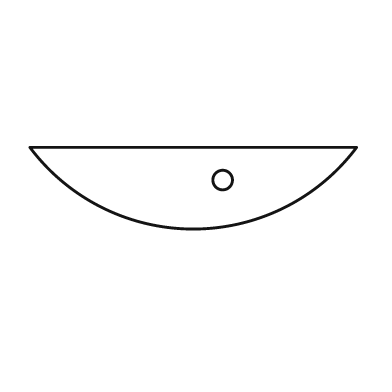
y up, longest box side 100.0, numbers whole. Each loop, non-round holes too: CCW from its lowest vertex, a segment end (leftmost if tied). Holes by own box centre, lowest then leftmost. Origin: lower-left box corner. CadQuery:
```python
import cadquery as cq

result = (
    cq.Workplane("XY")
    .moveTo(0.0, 25.0)
    .threePointArc((50.0, 0.0), (100.0, 25.0))
    .close()
    .moveTo(59.0, 15.0)
    .circle(3.0)
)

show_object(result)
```